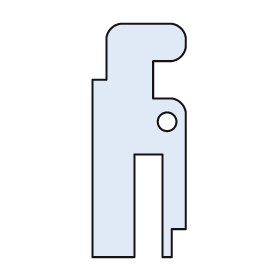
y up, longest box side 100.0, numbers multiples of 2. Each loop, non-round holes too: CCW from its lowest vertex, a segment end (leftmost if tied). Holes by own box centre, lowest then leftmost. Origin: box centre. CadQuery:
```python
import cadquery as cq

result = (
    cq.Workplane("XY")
    .moveTo(-20.0, -50.0)
    .lineTo(-2.0, -50.0)
    .lineTo(-2.0, -6.0)
    .lineTo(10.0, -6.0)
    .lineTo(10.0, -50.0)
    .lineTo(14.0, -50.0)
    .lineTo(14.0, -38.0)
    .lineTo(20.0, -38.0)
    .lineTo(20.0, 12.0)
    .threePointArc((18.0, 16.0), (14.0, 18.0))
    .lineTo(6.0, 18.0)
    .lineTo(6.0, 34.0)
    .lineTo(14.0, 34.0)
    .threePointArc((18.0, 36.0), (20.0, 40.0))
    .lineTo(20.0, 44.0)
    .threePointArc((18.0, 48.0), (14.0, 50.0))
    .lineTo(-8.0, 50.0)
    .threePointArc((-12.0, 48.0), (-14.0, 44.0))
    .lineTo(-14.0, 26.0)
    .lineTo(-20.0, 26.0)
    .close()
    .moveTo(12.0, 8.0)
    .circle(4.0)
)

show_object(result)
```